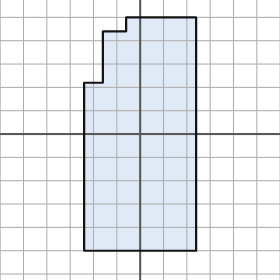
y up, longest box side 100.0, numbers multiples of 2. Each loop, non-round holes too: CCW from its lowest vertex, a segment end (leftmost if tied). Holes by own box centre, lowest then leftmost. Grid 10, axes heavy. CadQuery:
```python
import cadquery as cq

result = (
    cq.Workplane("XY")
    .moveTo(-24.0, -50.0)
    .lineTo(24.0, -50.0)
    .lineTo(24.0, 50.0)
    .lineTo(-6.0, 50.0)
    .lineTo(-6.0, 44.0)
    .lineTo(-16.0, 44.0)
    .lineTo(-16.0, 22.0)
    .lineTo(-24.0, 22.0)
    .close()
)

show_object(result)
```